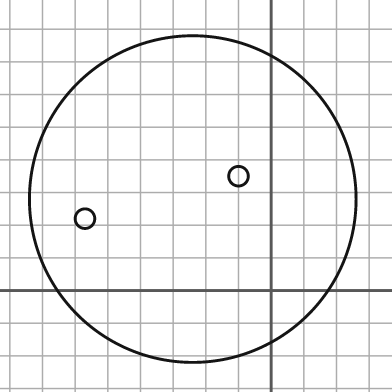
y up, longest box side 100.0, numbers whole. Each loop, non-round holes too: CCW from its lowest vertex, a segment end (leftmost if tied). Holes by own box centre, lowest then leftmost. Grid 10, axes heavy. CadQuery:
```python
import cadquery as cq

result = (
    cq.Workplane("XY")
    .moveTo(-24.0, 28.0)
    .circle(50.0)
    .moveTo(-57.0, 22.0)
    .circle(3.0)
    .moveTo(-10.0, 35.0)
    .circle(3.0)
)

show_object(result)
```